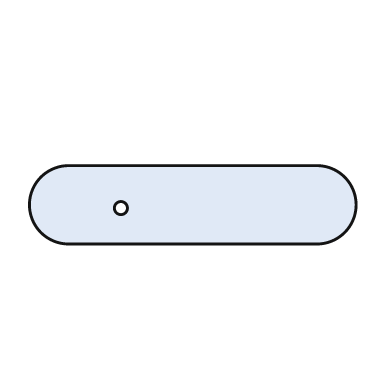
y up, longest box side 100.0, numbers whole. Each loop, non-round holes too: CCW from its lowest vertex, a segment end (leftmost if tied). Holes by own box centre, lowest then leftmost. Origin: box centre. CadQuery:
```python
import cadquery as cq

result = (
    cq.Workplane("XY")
    .moveTo(-38.0, -12.0)
    .lineTo(38.0, -12.0)
    .threePointArc((50.0, 0.0), (38.0, 12.0))
    .lineTo(-38.0, 12.0)
    .threePointArc((-50.0, 0.0), (-38.0, -12.0))
    .close()
    .moveTo(-22.0, -1.0)
    .circle(2.0)
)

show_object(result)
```